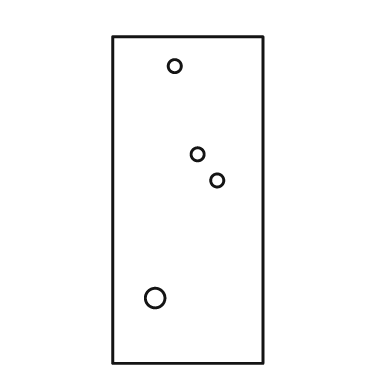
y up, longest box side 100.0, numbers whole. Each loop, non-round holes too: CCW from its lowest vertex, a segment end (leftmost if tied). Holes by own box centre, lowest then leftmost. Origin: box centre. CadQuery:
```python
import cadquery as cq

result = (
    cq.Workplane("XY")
    .moveTo(-23.0, -50.0)
    .lineTo(23.0, -50.0)
    .lineTo(23.0, 50.0)
    .lineTo(-23.0, 50.0)
    .close()
    .moveTo(-10.0, -30.0)
    .circle(3.0)
    .moveTo(9.0, 6.0)
    .circle(2.0)
    .moveTo(3.0, 14.0)
    .circle(2.0)
    .moveTo(-4.0, 41.0)
    .circle(2.0)
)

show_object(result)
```